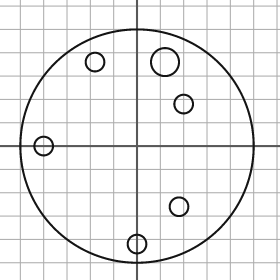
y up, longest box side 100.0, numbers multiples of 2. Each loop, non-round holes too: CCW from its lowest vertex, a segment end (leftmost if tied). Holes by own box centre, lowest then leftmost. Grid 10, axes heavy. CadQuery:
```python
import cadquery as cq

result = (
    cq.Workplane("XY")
    .moveTo(0.0, 0.0)
    .circle(50.0)
    .moveTo(0.0, -42.0)
    .circle(4.0)
    .moveTo(18.0, -26.0)
    .circle(4.0)
    .moveTo(-40.0, 0.0)
    .circle(4.0)
    .moveTo(20.0, 18.0)
    .circle(4.0)
    .moveTo(-18.0, 36.0)
    .circle(4.0)
    .moveTo(12.0, 36.0)
    .circle(6.0)
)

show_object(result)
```